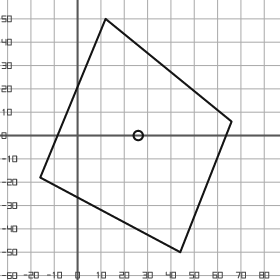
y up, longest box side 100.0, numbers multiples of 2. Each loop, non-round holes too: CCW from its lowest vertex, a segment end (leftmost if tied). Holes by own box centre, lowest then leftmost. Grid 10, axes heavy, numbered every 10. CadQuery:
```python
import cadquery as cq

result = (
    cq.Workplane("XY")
    .moveTo(44.0, -50.0)
    .lineTo(66.0, 6.0)
    .lineTo(12.0, 50.0)
    .lineTo(-16.0, -18.0)
    .close()
    .moveTo(26.0, 0.0)
    .circle(2.0)
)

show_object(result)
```